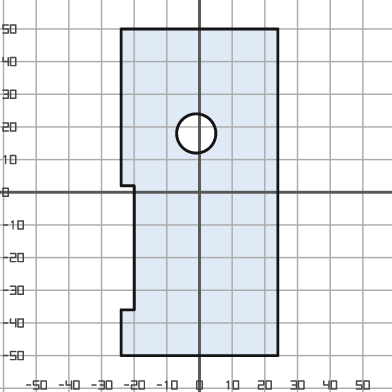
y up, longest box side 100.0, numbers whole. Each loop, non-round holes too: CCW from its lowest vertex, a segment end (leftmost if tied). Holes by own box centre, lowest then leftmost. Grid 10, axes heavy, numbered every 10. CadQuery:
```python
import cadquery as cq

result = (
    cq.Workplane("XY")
    .moveTo(-24.0, -50.0)
    .lineTo(24.0, -50.0)
    .lineTo(24.0, 50.0)
    .lineTo(-24.0, 50.0)
    .lineTo(-24.0, 2.0)
    .lineTo(-20.0, 2.0)
    .lineTo(-20.0, -36.0)
    .lineTo(-24.0, -36.0)
    .close()
    .moveTo(-1.0, 18.0)
    .circle(6.0)
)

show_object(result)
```